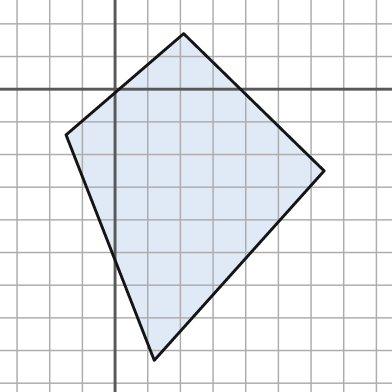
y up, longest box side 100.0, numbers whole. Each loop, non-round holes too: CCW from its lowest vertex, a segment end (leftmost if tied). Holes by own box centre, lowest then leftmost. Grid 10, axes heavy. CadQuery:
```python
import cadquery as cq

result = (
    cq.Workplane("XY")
    .moveTo(12.0, -83.0)
    .lineTo(64.0, -25.0)
    .lineTo(21.0, 17.0)
    .lineTo(-15.0, -14.0)
    .close()
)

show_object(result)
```